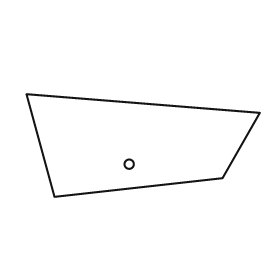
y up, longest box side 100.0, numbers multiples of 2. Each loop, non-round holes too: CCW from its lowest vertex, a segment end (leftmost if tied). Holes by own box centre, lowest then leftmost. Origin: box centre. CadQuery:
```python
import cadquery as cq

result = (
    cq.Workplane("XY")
    .moveTo(-38.0, -22.0)
    .lineTo(34.0, -14.0)
    .lineTo(50.0, 14.0)
    .lineTo(-50.0, 22.0)
    .close()
    .moveTo(-6.0, -8.0)
    .circle(2.0)
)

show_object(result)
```